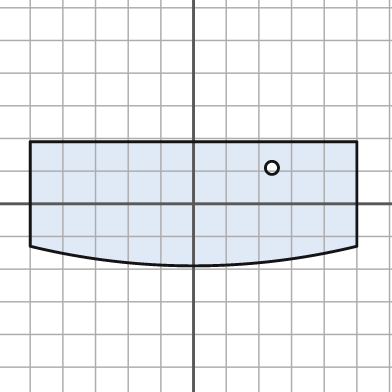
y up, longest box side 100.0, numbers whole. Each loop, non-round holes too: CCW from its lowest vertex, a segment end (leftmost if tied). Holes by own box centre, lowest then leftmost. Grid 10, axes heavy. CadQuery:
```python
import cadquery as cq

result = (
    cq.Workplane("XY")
    .moveTo(-50.0, -13.0)
    .threePointArc((0.0, -19.0), (50.0, -13.0))
    .lineTo(50.0, 19.0)
    .lineTo(-50.0, 19.0)
    .close()
    .moveTo(24.0, 11.0)
    .circle(2.0)
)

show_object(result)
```